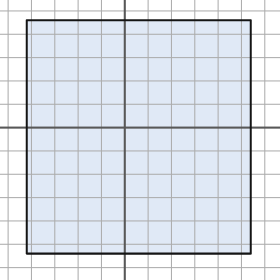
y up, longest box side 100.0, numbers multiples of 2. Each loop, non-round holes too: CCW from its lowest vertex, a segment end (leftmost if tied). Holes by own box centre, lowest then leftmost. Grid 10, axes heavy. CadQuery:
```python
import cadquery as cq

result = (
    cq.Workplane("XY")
    .moveTo(-42.0, -54.0)
    .lineTo(54.0, -54.0)
    .lineTo(54.0, 46.0)
    .lineTo(-42.0, 46.0)
    .close()
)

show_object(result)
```